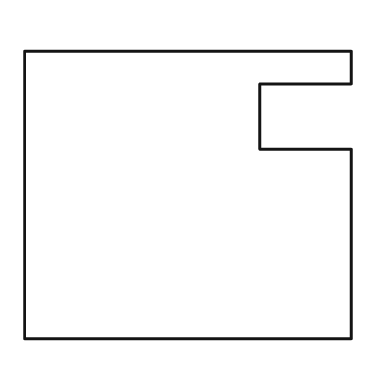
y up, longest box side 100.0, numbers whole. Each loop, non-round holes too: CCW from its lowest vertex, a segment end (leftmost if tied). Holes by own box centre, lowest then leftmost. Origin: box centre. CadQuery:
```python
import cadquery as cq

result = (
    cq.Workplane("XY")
    .moveTo(-50.0, -44.0)
    .lineTo(50.0, -44.0)
    .lineTo(50.0, 14.0)
    .lineTo(22.0, 14.0)
    .lineTo(22.0, 34.0)
    .lineTo(50.0, 34.0)
    .lineTo(50.0, 44.0)
    .lineTo(-50.0, 44.0)
    .close()
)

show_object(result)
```